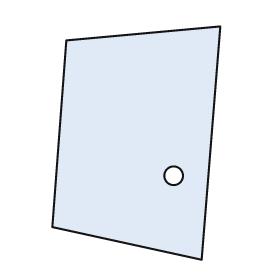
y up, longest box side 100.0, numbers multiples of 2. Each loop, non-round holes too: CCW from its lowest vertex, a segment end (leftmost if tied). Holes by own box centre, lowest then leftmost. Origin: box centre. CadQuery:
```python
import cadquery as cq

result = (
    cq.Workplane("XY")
    .moveTo(28.0, -50.0)
    .lineTo(36.0, 50.0)
    .lineTo(-30.0, 44.0)
    .lineTo(-36.0, -36.0)
    .close()
    .moveTo(16.0, -14.0)
    .circle(4.0)
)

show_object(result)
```